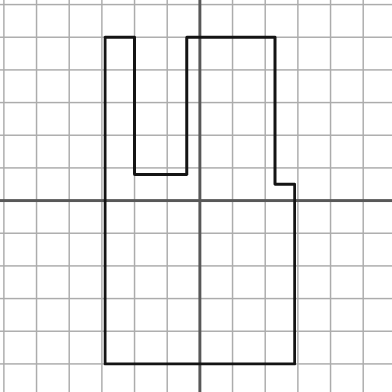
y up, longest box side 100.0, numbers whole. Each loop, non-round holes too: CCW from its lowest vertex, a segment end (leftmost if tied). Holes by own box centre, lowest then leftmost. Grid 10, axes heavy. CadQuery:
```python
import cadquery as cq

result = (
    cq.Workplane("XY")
    .moveTo(-29.0, -50.0)
    .lineTo(29.0, -50.0)
    .lineTo(29.0, 5.0)
    .lineTo(23.0, 5.0)
    .lineTo(23.0, 50.0)
    .lineTo(-4.0, 50.0)
    .lineTo(-4.0, 8.0)
    .lineTo(-20.0, 8.0)
    .lineTo(-20.0, 50.0)
    .lineTo(-29.0, 50.0)
    .close()
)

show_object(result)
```